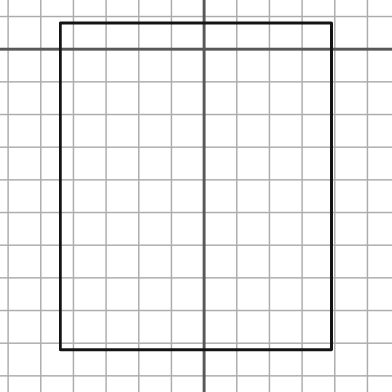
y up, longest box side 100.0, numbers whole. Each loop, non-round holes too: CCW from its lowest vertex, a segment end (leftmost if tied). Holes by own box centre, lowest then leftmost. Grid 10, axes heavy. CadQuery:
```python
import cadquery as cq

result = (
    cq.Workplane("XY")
    .moveTo(-44.0, -92.0)
    .lineTo(39.0, -92.0)
    .lineTo(39.0, 8.0)
    .lineTo(-44.0, 8.0)
    .close()
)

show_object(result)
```